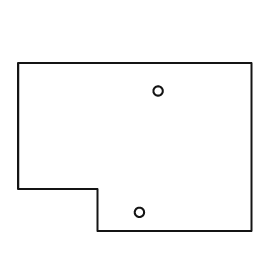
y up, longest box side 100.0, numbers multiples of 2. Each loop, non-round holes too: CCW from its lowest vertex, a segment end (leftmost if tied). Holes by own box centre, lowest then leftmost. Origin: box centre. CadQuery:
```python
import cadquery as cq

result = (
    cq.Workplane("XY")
    .moveTo(-16.0, -36.0)
    .lineTo(50.0, -36.0)
    .lineTo(50.0, 36.0)
    .lineTo(-50.0, 36.0)
    .lineTo(-50.0, -18.0)
    .lineTo(-16.0, -18.0)
    .close()
    .moveTo(2.0, -28.0)
    .circle(2.0)
    .moveTo(10.0, 24.0)
    .circle(2.0)
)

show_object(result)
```